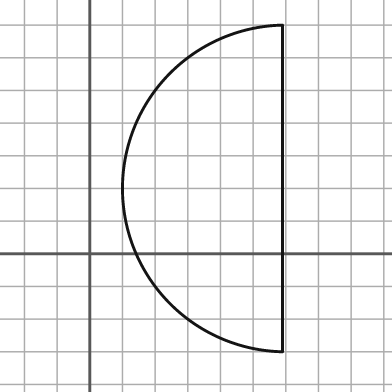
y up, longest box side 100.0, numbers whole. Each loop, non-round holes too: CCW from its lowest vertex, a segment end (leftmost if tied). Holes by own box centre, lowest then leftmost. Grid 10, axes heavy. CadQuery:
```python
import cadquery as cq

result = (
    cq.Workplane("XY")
    .moveTo(59.0, -30.0)
    .lineTo(59.0, 70.0)
    .threePointArc((10.0, 20.0), (59.0, -30.0))
    .close()
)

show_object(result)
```